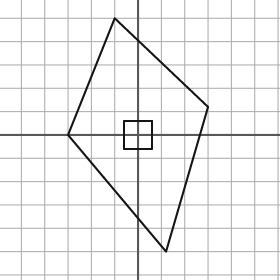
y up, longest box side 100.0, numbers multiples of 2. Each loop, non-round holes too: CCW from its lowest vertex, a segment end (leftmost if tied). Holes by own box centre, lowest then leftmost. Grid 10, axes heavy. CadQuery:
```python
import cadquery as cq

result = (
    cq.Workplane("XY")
    .moveTo(12.0, -50.0)
    .lineTo(30.0, 12.0)
    .lineTo(-10.0, 50.0)
    .lineTo(-30.0, 0.0)
    .close()
    .moveTo(-6.0, -6.0)
    .lineTo(6.0, -6.0)
    .lineTo(6.0, 6.0)
    .lineTo(-6.0, 6.0)
    .close()
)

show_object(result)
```